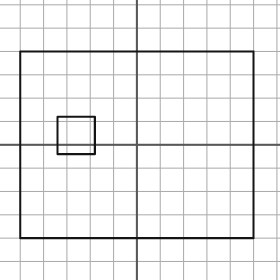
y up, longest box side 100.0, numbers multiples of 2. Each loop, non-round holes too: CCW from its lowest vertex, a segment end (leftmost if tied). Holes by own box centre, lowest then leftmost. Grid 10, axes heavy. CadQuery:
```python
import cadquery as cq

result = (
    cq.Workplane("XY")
    .moveTo(-50.0, -40.0)
    .lineTo(50.0, -40.0)
    .lineTo(50.0, 40.0)
    .lineTo(-50.0, 40.0)
    .close()
    .moveTo(-34.0, -4.0)
    .lineTo(-18.0, -4.0)
    .lineTo(-18.0, 12.0)
    .lineTo(-34.0, 12.0)
    .close()
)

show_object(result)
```